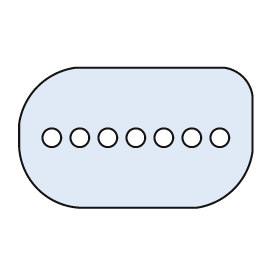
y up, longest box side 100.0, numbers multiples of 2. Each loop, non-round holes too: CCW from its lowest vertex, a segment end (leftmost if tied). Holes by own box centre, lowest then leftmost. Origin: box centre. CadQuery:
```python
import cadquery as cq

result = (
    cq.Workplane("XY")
    .moveTo(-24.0, -30.0)
    .lineTo(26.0, -30.0)
    .threePointArc((42.0, -22.0), (50.0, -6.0))
    .lineTo(50.0, 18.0)
    .threePointArc((46.0, 26.0), (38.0, 30.0))
    .lineTo(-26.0, 30.0)
    .threePointArc((-42.0, 22.0), (-50.0, 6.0))
    .lineTo(-50.0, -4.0)
    .threePointArc((-42.0, -22.0), (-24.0, -30.0))
    .close()
    .moveTo(-36.0, 0.0)
    .circle(4.0)
    .moveTo(-24.0, 0.0)
    .circle(4.0)
    .moveTo(-12.0, 0.0)
    .circle(4.0)
    .moveTo(0.0, 0.0)
    .circle(4.0)
    .moveTo(12.0, 0.0)
    .circle(4.0)
    .moveTo(24.0, 0.0)
    .circle(4.0)
    .moveTo(36.0, 0.0)
    .circle(4.0)
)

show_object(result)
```